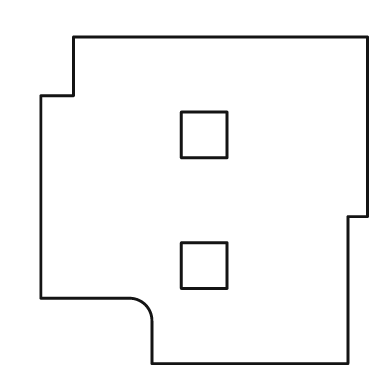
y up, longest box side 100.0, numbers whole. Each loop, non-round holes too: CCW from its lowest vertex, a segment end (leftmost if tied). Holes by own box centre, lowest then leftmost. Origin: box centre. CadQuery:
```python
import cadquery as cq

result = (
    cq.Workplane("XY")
    .moveTo(-16.0, -50.0)
    .lineTo(44.0, -50.0)
    .lineTo(44.0, -5.0)
    .lineTo(50.0, -5.0)
    .lineTo(50.0, 50.0)
    .lineTo(-40.0, 50.0)
    .lineTo(-40.0, 32.0)
    .lineTo(-50.0, 32.0)
    .lineTo(-50.0, -30.0)
    .lineTo(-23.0, -30.0)
    .threePointArc((-18.0, -32.0), (-16.0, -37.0))
    .close()
    .moveTo(-7.0, -27.0)
    .lineTo(7.0, -27.0)
    .lineTo(7.0, -13.0)
    .lineTo(-7.0, -13.0)
    .close()
    .moveTo(-7.0, 13.0)
    .lineTo(7.0, 13.0)
    .lineTo(7.0, 27.0)
    .lineTo(-7.0, 27.0)
    .close()
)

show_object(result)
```